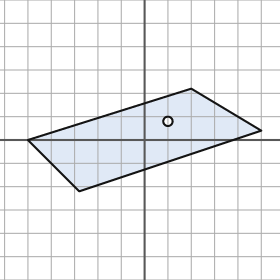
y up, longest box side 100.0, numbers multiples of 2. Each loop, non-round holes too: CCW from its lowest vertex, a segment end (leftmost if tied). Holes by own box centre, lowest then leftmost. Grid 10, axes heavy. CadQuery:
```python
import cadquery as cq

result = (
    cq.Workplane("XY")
    .moveTo(-28.0, -22.0)
    .lineTo(50.0, 4.0)
    .lineTo(20.0, 22.0)
    .lineTo(-50.0, 0.0)
    .close()
    .moveTo(10.0, 8.0)
    .circle(2.0)
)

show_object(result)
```